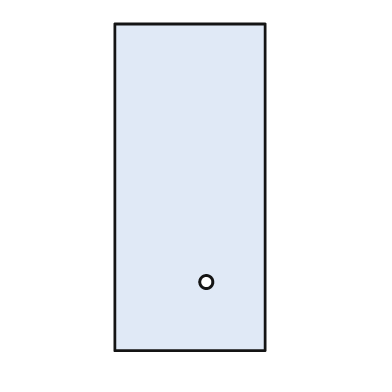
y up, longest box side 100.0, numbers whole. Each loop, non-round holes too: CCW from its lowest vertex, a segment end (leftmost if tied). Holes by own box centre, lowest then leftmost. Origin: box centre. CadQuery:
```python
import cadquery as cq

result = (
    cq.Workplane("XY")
    .moveTo(-23.0, -50.0)
    .lineTo(23.0, -50.0)
    .lineTo(23.0, 50.0)
    .lineTo(-23.0, 50.0)
    .close()
    .moveTo(5.0, -29.0)
    .circle(2.0)
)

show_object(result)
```